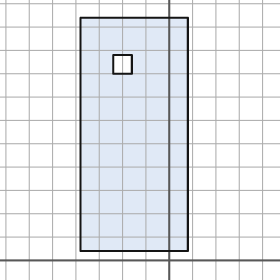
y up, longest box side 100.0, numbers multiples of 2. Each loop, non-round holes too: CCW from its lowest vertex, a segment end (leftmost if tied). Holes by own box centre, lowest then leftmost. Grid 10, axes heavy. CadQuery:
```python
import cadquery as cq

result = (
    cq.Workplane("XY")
    .moveTo(-38.0, 4.0)
    .lineTo(8.0, 4.0)
    .lineTo(8.0, 104.0)
    .lineTo(-38.0, 104.0)
    .close()
    .moveTo(-24.0, 80.0)
    .lineTo(-16.0, 80.0)
    .lineTo(-16.0, 88.0)
    .lineTo(-24.0, 88.0)
    .close()
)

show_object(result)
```